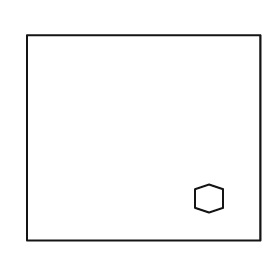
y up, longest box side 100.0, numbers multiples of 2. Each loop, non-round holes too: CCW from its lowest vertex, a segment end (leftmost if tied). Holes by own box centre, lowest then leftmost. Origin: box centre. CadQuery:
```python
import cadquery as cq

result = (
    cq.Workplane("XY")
    .moveTo(-50.0, -44.0)
    .lineTo(50.0, -44.0)
    .lineTo(50.0, 44.0)
    .lineTo(-50.0, 44.0)
    .close()
    .moveTo(28.0, -32.0)
    .lineTo(34.0, -30.0)
    .lineTo(34.0, -22.0)
    .lineTo(28.0, -20.0)
    .lineTo(22.0, -22.0)
    .lineTo(22.0, -30.0)
    .close()
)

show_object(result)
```